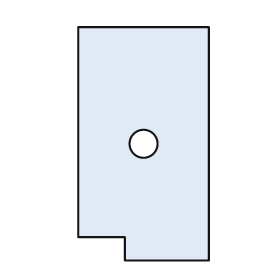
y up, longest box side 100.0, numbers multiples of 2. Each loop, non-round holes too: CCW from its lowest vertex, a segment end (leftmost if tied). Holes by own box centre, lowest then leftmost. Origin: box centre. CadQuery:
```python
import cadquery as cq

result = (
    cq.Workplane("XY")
    .moveTo(-8.0, -50.0)
    .lineTo(28.0, -50.0)
    .lineTo(28.0, 50.0)
    .lineTo(-28.0, 50.0)
    .lineTo(-28.0, -40.0)
    .lineTo(-8.0, -40.0)
    .close()
    .moveTo(0.0, 0.0)
    .circle(6.0)
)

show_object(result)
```